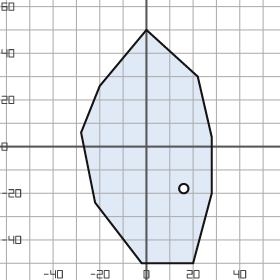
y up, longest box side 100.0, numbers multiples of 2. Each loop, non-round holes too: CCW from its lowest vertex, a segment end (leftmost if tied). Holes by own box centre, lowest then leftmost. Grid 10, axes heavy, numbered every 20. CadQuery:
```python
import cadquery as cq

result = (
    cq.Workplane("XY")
    .moveTo(-2.0, -50.0)
    .lineTo(20.0, -50.0)
    .lineTo(28.0, -20.0)
    .lineTo(28.0, 4.0)
    .lineTo(22.0, 30.0)
    .lineTo(0.0, 50.0)
    .lineTo(-20.0, 26.0)
    .lineTo(-28.0, 6.0)
    .lineTo(-22.0, -24.0)
    .close()
    .moveTo(16.0, -18.0)
    .circle(2.0)
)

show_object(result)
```